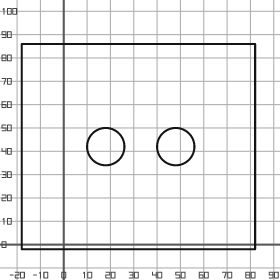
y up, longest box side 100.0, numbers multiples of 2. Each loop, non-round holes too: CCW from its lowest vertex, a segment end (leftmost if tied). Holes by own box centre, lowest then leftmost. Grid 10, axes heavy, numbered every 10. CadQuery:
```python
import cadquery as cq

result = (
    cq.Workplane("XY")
    .moveTo(-18.0, -2.0)
    .lineTo(82.0, -2.0)
    .lineTo(82.0, 86.0)
    .lineTo(-18.0, 86.0)
    .close()
    .moveTo(18.0, 42.0)
    .circle(8.0)
    .moveTo(48.0, 42.0)
    .circle(8.0)
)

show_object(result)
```